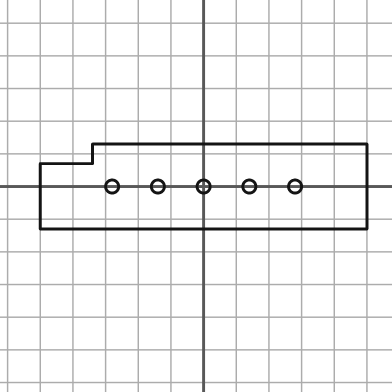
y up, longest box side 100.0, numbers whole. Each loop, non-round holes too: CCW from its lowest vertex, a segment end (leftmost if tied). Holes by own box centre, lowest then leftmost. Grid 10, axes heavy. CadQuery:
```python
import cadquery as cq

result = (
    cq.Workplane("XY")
    .moveTo(-50.0, -13.0)
    .lineTo(50.0, -13.0)
    .lineTo(50.0, 13.0)
    .lineTo(-34.0, 13.0)
    .lineTo(-34.0, 7.0)
    .lineTo(-50.0, 7.0)
    .close()
    .moveTo(-28.0, 0.0)
    .circle(2.0)
    .moveTo(-14.0, 0.0)
    .circle(2.0)
    .moveTo(0.0, 0.0)
    .circle(2.0)
    .moveTo(14.0, 0.0)
    .circle(2.0)
    .moveTo(28.0, 0.0)
    .circle(2.0)
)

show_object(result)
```